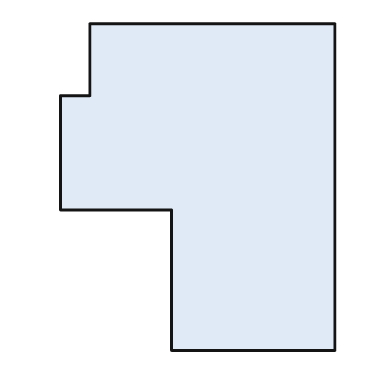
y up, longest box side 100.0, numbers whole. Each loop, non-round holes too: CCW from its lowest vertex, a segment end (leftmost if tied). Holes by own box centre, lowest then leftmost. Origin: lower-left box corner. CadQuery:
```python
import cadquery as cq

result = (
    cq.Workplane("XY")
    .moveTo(34.0, 0.0)
    .lineTo(84.0, 0.0)
    .lineTo(84.0, 100.0)
    .lineTo(9.0, 100.0)
    .lineTo(9.0, 78.0)
    .lineTo(0.0, 78.0)
    .lineTo(0.0, 43.0)
    .lineTo(34.0, 43.0)
    .close()
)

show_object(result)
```